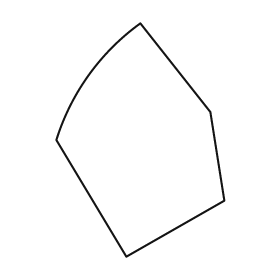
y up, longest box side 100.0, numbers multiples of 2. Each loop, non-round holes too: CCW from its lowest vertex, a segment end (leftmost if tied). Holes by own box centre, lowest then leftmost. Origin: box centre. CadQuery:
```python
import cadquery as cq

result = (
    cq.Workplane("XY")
    .moveTo(-6.0, -50.0)
    .lineTo(36.0, -26.0)
    .lineTo(30.0, 12.0)
    .lineTo(0.0, 50.0)
    .threePointArc((-22.0, 28.0), (-36.0, 0.0))
    .close()
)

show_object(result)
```